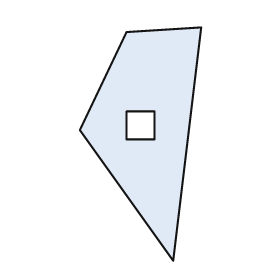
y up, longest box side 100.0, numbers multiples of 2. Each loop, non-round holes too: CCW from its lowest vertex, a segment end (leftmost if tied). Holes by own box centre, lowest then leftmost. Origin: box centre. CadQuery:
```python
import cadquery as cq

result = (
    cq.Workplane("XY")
    .moveTo(14.0, -50.0)
    .lineTo(26.0, 50.0)
    .lineTo(-6.0, 48.0)
    .lineTo(-26.0, 6.0)
    .close()
    .moveTo(-6.0, 2.0)
    .lineTo(6.0, 2.0)
    .lineTo(6.0, 14.0)
    .lineTo(-6.0, 14.0)
    .close()
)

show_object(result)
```